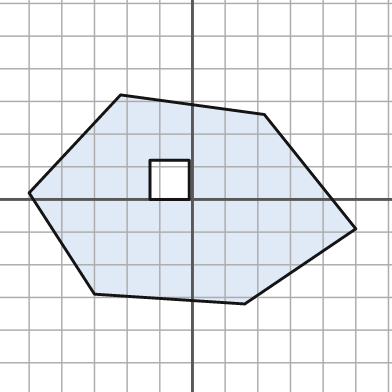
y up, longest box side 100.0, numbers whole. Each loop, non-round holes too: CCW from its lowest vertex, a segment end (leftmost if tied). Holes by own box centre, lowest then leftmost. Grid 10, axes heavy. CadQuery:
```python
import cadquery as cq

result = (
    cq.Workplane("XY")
    .moveTo(16.0, -32.0)
    .lineTo(50.0, -9.0)
    .lineTo(22.0, 26.0)
    .lineTo(-22.0, 32.0)
    .lineTo(-50.0, 2.0)
    .lineTo(-30.0, -29.0)
    .close()
    .moveTo(-13.0, 0.0)
    .lineTo(-1.0, 0.0)
    .lineTo(-1.0, 12.0)
    .lineTo(-13.0, 12.0)
    .close()
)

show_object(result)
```